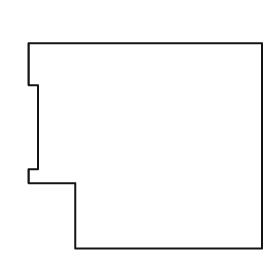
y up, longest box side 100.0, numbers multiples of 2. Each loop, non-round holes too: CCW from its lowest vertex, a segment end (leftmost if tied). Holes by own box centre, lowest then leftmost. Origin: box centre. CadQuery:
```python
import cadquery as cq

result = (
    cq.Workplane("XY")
    .moveTo(-30.0, -44.0)
    .lineTo(50.0, -44.0)
    .lineTo(50.0, 44.0)
    .lineTo(-50.0, 44.0)
    .lineTo(-50.0, 26.0)
    .lineTo(-46.0, 26.0)
    .lineTo(-46.0, -10.0)
    .lineTo(-50.0, -10.0)
    .lineTo(-50.0, -16.0)
    .lineTo(-30.0, -16.0)
    .close()
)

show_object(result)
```